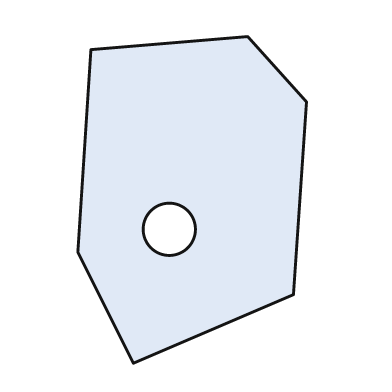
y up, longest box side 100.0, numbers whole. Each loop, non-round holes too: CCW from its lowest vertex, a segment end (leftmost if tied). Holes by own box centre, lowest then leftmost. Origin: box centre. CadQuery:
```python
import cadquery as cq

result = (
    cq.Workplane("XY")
    .moveTo(-18.0, -50.0)
    .lineTo(31.0, -29.0)
    .lineTo(35.0, 30.0)
    .lineTo(17.0, 50.0)
    .lineTo(-31.0, 46.0)
    .lineTo(-35.0, -16.0)
    .close()
    .moveTo(-7.0, -9.0)
    .circle(8.0)
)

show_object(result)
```